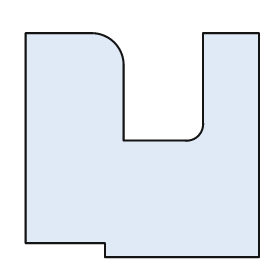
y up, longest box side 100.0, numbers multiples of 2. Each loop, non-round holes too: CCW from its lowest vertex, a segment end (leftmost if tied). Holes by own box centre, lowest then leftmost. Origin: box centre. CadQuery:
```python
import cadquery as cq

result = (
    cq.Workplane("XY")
    .moveTo(-16.0, -48.0)
    .lineTo(50.0, -48.0)
    .lineTo(50.0, 48.0)
    .lineTo(26.0, 48.0)
    .lineTo(26.0, 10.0)
    .threePointArc((24.0, 4.0), (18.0, 2.0))
    .lineTo(-8.0, 2.0)
    .lineTo(-8.0, 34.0)
    .threePointArc((-12.0, 44.0), (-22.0, 48.0))
    .lineTo(-50.0, 48.0)
    .lineTo(-50.0, -42.0)
    .lineTo(-16.0, -42.0)
    .close()
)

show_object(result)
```